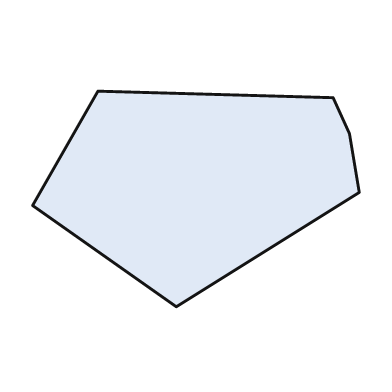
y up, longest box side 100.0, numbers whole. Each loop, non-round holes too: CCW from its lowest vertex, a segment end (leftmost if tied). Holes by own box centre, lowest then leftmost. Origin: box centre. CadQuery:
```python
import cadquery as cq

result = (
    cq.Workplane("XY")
    .moveTo(-6.0, -33.0)
    .lineTo(50.0, 2.0)
    .lineTo(47.0, 20.0)
    .lineTo(42.0, 31.0)
    .lineTo(-30.0, 33.0)
    .lineTo(-50.0, -2.0)
    .close()
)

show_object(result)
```